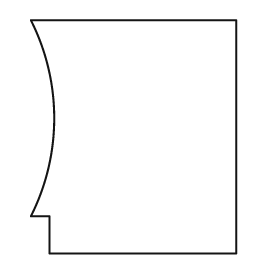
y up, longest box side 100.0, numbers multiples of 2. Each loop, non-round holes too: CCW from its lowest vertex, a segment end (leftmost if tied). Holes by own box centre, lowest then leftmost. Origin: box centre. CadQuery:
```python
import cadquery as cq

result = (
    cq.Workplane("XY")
    .moveTo(-36.0, -50.0)
    .lineTo(44.0, -50.0)
    .lineTo(44.0, 50.0)
    .lineTo(-44.0, 50.0)
    .threePointArc((-34.0, 8.0), (-44.0, -34.0))
    .lineTo(-36.0, -34.0)
    .close()
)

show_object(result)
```